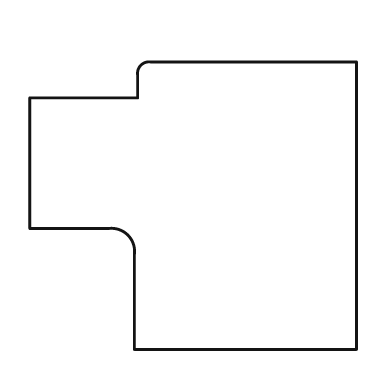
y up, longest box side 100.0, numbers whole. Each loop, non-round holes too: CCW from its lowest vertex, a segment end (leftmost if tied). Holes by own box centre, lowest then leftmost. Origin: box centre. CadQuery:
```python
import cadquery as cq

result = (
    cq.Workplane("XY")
    .moveTo(-18.0, -44.0)
    .lineTo(50.0, -44.0)
    .lineTo(50.0, 44.0)
    .lineTo(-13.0, 44.0)
    .threePointArc((-16.0, 43.0), (-17.0, 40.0))
    .lineTo(-17.0, 33.0)
    .lineTo(-50.0, 33.0)
    .lineTo(-50.0, -7.0)
    .lineTo(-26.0, -7.0)
    .threePointArc((-20.0, -9.0), (-18.0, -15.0))
    .close()
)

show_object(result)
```